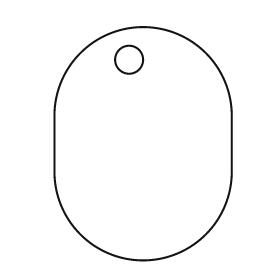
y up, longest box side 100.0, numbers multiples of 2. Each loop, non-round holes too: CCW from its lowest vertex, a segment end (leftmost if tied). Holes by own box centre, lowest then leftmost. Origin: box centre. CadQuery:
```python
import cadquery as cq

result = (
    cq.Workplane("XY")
    .moveTo(-38.0, -12.0)
    .threePointArc((0.0, -50.0), (38.0, -12.0))
    .lineTo(38.0, 12.0)
    .threePointArc((0.0, 50.0), (-38.0, 12.0))
    .close()
    .moveTo(-6.0, 36.0)
    .circle(6.0)
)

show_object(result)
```